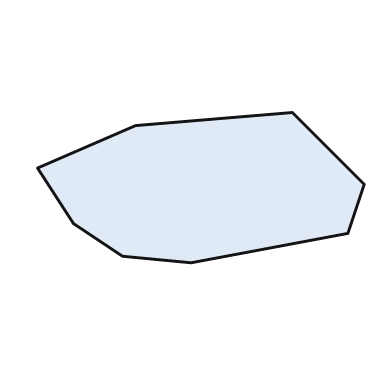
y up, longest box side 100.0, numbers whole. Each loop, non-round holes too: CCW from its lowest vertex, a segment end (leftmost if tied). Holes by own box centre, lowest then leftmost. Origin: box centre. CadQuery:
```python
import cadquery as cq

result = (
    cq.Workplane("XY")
    .moveTo(-3.0, -23.0)
    .lineTo(45.0, -14.0)
    .lineTo(50.0, 1.0)
    .lineTo(28.0, 23.0)
    .lineTo(-20.0, 19.0)
    .lineTo(-50.0, 6.0)
    .lineTo(-39.0, -11.0)
    .lineTo(-24.0, -21.0)
    .close()
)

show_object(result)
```